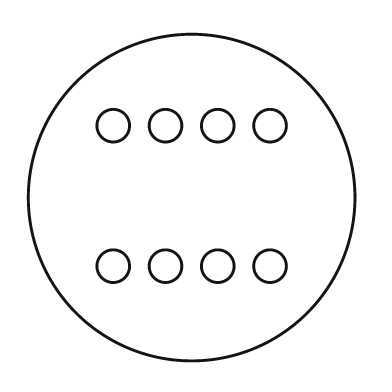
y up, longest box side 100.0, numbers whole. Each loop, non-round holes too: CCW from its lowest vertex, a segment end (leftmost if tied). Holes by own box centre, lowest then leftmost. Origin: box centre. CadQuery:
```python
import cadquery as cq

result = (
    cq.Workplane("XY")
    .moveTo(0.0, 0.0)
    .circle(50.0)
    .moveTo(-24.0, -21.0)
    .circle(5.0)
    .moveTo(-8.0, -21.0)
    .circle(5.0)
    .moveTo(8.0, -21.0)
    .circle(5.0)
    .moveTo(24.0, -21.0)
    .circle(5.0)
    .moveTo(-24.0, 22.0)
    .circle(5.0)
    .moveTo(-8.0, 22.0)
    .circle(5.0)
    .moveTo(8.0, 22.0)
    .circle(5.0)
    .moveTo(24.0, 22.0)
    .circle(5.0)
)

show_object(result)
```